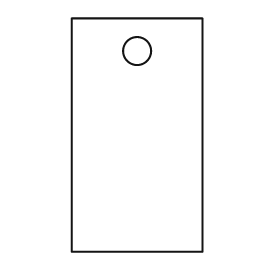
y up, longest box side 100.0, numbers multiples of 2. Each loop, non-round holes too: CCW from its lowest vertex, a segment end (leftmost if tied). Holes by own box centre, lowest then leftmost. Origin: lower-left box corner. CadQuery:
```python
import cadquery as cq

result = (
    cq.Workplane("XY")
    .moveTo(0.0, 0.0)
    .lineTo(56.0, 0.0)
    .lineTo(56.0, 100.0)
    .lineTo(0.0, 100.0)
    .close()
    .moveTo(28.0, 86.0)
    .circle(6.0)
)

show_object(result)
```